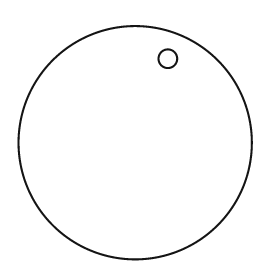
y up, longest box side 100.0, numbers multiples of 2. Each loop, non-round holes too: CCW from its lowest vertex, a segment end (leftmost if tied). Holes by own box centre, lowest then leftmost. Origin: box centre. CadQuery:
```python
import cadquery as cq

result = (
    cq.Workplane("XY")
    .moveTo(0.0, 0.0)
    .circle(50.0)
    .moveTo(14.0, 36.0)
    .circle(4.0)
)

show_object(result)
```